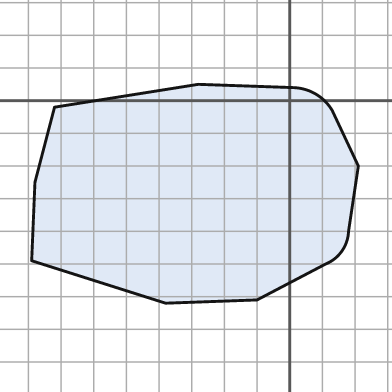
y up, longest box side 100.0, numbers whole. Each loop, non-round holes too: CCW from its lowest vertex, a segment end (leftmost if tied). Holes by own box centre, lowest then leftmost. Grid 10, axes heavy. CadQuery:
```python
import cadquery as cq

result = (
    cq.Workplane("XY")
    .moveTo(-38.0, -62.0)
    .lineTo(-10.0, -61.0)
    .lineTo(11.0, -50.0)
    .threePointArc((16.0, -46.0), (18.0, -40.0))
    .lineTo(21.0, -20.0)
    .lineTo(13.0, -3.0)
    .threePointArc((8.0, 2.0), (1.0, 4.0))
    .lineTo(-28.0, 5.0)
    .lineTo(-72.0, -2.0)
    .lineTo(-78.0, -25.0)
    .lineTo(-79.0, -49.0)
    .close()
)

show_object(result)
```